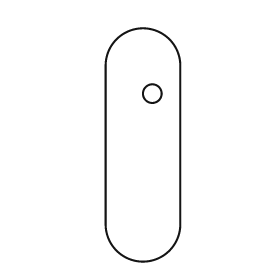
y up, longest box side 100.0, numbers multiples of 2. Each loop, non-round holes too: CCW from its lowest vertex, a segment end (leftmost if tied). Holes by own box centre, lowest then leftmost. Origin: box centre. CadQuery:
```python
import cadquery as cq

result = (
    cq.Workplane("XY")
    .moveTo(-16.0, -34.0)
    .threePointArc((0.0, -50.0), (16.0, -34.0))
    .lineTo(16.0, 34.0)
    .threePointArc((0.0, 50.0), (-16.0, 34.0))
    .close()
    .moveTo(4.0, 22.0)
    .circle(4.0)
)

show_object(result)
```